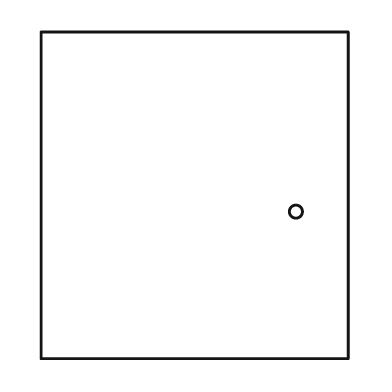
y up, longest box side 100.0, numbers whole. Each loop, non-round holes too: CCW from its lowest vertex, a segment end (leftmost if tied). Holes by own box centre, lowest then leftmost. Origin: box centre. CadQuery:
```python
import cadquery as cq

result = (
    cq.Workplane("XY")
    .moveTo(-47.0, -50.0)
    .lineTo(47.0, -50.0)
    .lineTo(47.0, 50.0)
    .lineTo(-47.0, 50.0)
    .close()
    .moveTo(31.0, -5.0)
    .circle(2.0)
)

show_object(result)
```